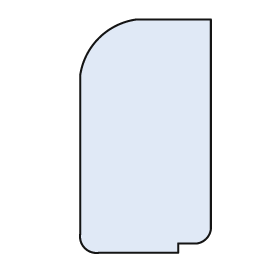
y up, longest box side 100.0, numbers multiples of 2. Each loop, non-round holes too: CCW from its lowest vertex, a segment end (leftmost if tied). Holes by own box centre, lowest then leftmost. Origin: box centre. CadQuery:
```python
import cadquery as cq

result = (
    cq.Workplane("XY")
    .moveTo(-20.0, -50.0)
    .lineTo(14.0, -50.0)
    .lineTo(14.0, -46.0)
    .lineTo(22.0, -46.0)
    .threePointArc((26.0, -44.0), (28.0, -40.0))
    .lineTo(28.0, 50.0)
    .lineTo(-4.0, 50.0)
    .threePointArc((-20.0, 42.0), (-28.0, 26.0))
    .lineTo(-28.0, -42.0)
    .threePointArc((-26.0, -48.0), (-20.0, -50.0))
    .close()
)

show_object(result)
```